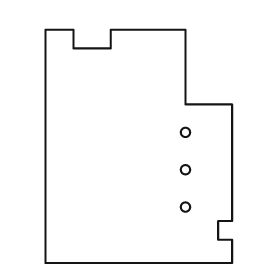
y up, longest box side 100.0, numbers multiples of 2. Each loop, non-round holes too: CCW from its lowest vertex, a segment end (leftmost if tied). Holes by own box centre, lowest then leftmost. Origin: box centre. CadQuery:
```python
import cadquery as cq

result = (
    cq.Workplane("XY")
    .moveTo(-40.0, -50.0)
    .lineTo(40.0, -50.0)
    .lineTo(40.0, -40.0)
    .lineTo(34.0, -40.0)
    .lineTo(34.0, -32.0)
    .lineTo(40.0, -32.0)
    .lineTo(40.0, 18.0)
    .lineTo(20.0, 18.0)
    .lineTo(20.0, 50.0)
    .lineTo(-12.0, 50.0)
    .lineTo(-12.0, 42.0)
    .lineTo(-28.0, 42.0)
    .lineTo(-28.0, 50.0)
    .lineTo(-40.0, 50.0)
    .close()
    .moveTo(20.0, -26.0)
    .circle(2.0)
    .moveTo(20.0, -10.0)
    .circle(2.0)
    .moveTo(20.0, 6.0)
    .circle(2.0)
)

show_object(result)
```